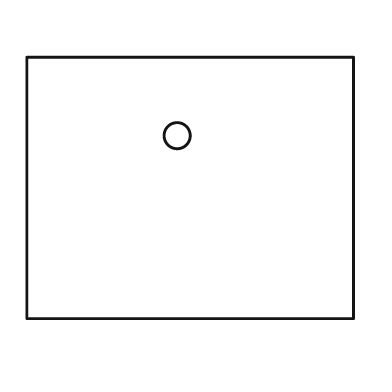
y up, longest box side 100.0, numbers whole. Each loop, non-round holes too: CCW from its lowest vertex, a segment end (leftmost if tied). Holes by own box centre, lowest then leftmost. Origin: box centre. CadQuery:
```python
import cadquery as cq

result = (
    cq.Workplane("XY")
    .moveTo(-50.0, -40.0)
    .lineTo(50.0, -40.0)
    .lineTo(50.0, 40.0)
    .lineTo(-50.0, 40.0)
    .close()
    .moveTo(-4.0, 16.0)
    .circle(4.0)
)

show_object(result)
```